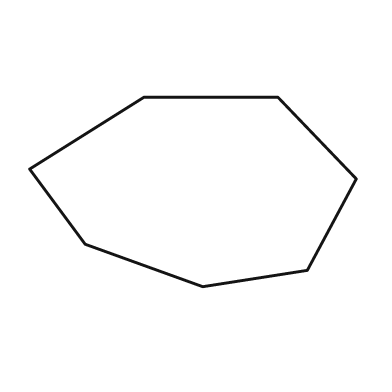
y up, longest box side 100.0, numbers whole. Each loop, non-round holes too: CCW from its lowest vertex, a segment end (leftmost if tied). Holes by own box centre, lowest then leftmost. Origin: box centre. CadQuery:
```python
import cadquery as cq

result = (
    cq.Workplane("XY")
    .moveTo(3.0, -29.0)
    .lineTo(35.0, -24.0)
    .lineTo(50.0, 4.0)
    .lineTo(26.0, 29.0)
    .lineTo(-15.0, 29.0)
    .lineTo(-50.0, 7.0)
    .lineTo(-33.0, -16.0)
    .close()
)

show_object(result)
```